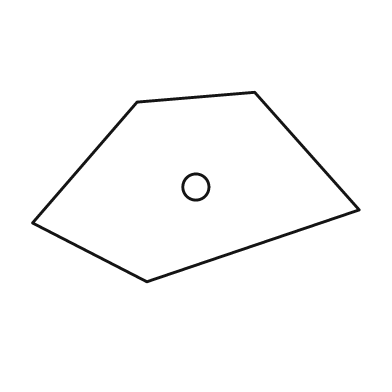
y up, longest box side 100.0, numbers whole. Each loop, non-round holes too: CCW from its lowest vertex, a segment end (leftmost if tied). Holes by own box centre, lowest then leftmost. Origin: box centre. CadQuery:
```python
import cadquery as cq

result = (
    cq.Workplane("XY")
    .moveTo(-15.0, -29.0)
    .lineTo(50.0, -7.0)
    .lineTo(18.0, 29.0)
    .lineTo(-18.0, 26.0)
    .lineTo(-50.0, -11.0)
    .close()
    .moveTo(0.0, 0.0)
    .circle(4.0)
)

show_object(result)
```